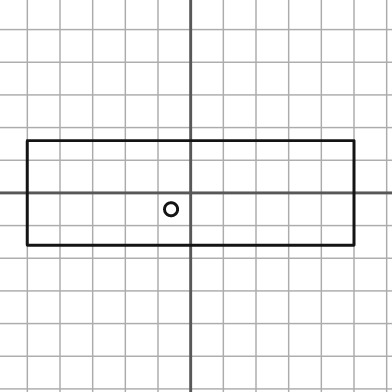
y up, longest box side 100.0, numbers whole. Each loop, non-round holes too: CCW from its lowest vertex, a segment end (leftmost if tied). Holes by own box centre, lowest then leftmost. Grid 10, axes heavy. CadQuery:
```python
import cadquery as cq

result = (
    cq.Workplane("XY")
    .moveTo(-50.0, -16.0)
    .lineTo(50.0, -16.0)
    .lineTo(50.0, 16.0)
    .lineTo(-50.0, 16.0)
    .close()
    .moveTo(-6.0, -5.0)
    .circle(2.0)
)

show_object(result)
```